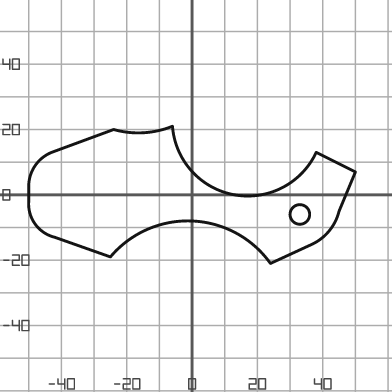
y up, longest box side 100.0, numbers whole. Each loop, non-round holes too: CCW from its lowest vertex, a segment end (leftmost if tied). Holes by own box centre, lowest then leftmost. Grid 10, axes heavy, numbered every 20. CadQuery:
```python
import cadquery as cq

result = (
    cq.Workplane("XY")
    .moveTo(24.0, -21.0)
    .lineTo(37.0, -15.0)
    .threePointArc((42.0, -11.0), (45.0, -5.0))
    .lineTo(50.0, 7.0)
    .lineTo(38.0, 13.0)
    .threePointArc((13.0, 0.0), (-6.0, 21.0))
    .threePointArc((-15.0, 19.0), (-24.0, 20.0))
    .lineTo(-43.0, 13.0)
    .threePointArc((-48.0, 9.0), (-50.0, 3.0))
    .lineTo(-50.0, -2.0)
    .threePointArc((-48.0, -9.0), (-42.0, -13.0))
    .lineTo(-25.0, -19.0)
    .threePointArc((0.0, -8.0), (24.0, -21.0))
    .close()
    .moveTo(33.0, -6.0)
    .circle(3.0)
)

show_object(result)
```